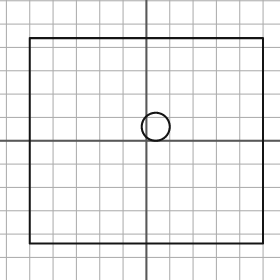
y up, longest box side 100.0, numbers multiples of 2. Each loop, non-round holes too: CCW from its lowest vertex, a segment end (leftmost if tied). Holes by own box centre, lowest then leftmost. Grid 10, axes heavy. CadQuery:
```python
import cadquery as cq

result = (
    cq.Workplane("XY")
    .moveTo(-50.0, -44.0)
    .lineTo(50.0, -44.0)
    .lineTo(50.0, 44.0)
    .lineTo(-50.0, 44.0)
    .close()
    .moveTo(4.0, 6.0)
    .circle(6.0)
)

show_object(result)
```